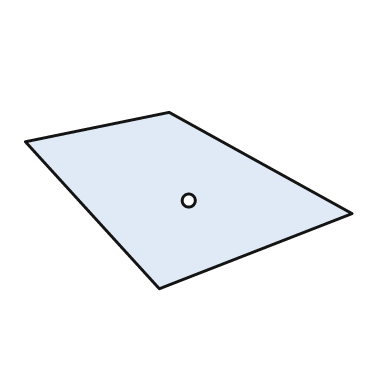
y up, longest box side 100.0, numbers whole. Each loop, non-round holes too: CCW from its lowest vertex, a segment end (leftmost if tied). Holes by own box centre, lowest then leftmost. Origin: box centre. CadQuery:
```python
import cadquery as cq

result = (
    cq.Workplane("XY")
    .moveTo(-9.0, -27.0)
    .lineTo(50.0, -4.0)
    .lineTo(-6.0, 27.0)
    .lineTo(-50.0, 18.0)
    .close()
    .moveTo(0.0, 0.0)
    .circle(2.0)
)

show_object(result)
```